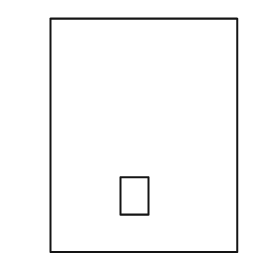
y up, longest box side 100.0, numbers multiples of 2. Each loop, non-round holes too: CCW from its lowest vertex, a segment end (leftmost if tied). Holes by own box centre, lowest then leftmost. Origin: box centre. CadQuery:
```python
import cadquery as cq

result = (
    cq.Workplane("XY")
    .moveTo(-40.0, -50.0)
    .lineTo(40.0, -50.0)
    .lineTo(40.0, 50.0)
    .lineTo(-40.0, 50.0)
    .close()
    .moveTo(-10.0, -34.0)
    .lineTo(2.0, -34.0)
    .lineTo(2.0, -18.0)
    .lineTo(-10.0, -18.0)
    .close()
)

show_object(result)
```